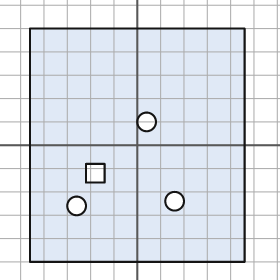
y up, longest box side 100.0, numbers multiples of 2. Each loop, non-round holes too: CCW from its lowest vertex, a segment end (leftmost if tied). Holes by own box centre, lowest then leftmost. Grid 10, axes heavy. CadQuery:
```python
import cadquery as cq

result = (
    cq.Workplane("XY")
    .moveTo(-46.0, -50.0)
    .lineTo(46.0, -50.0)
    .lineTo(46.0, 50.0)
    .lineTo(-46.0, 50.0)
    .close()
    .moveTo(-26.0, -26.0)
    .circle(4.0)
    .moveTo(16.0, -24.0)
    .circle(4.0)
    .moveTo(-22.0, -16.0)
    .lineTo(-14.0, -16.0)
    .lineTo(-14.0, -8.0)
    .lineTo(-22.0, -8.0)
    .close()
    .moveTo(4.0, 10.0)
    .circle(4.0)
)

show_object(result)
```